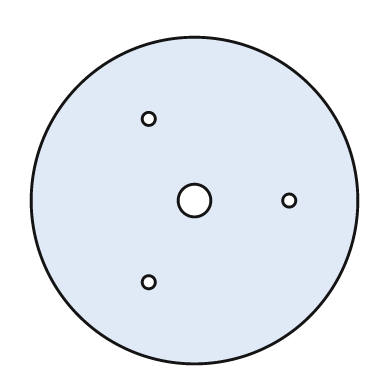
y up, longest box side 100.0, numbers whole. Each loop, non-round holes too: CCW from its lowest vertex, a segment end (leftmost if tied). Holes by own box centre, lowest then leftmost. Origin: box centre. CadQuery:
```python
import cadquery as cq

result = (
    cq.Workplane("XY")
    .moveTo(0.0, 0.0)
    .circle(50.0)
    .moveTo(-14.0, -25.0)
    .circle(2.0)
    .moveTo(0.0, 0.0)
    .circle(5.0)
    .moveTo(29.0, 0.0)
    .circle(2.0)
    .moveTo(-14.0, 25.0)
    .circle(2.0)
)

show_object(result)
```